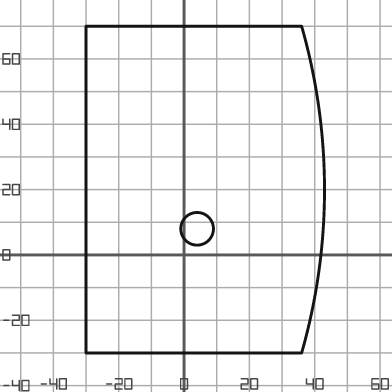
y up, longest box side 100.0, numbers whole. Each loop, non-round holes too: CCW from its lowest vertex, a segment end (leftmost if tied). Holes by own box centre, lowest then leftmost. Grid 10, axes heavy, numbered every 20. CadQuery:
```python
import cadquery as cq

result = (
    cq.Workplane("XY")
    .moveTo(-30.0, -30.0)
    .lineTo(36.0, -30.0)
    .threePointArc((43.0, 20.0), (36.0, 70.0))
    .lineTo(-30.0, 70.0)
    .close()
    .moveTo(4.0, 8.0)
    .circle(5.0)
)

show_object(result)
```